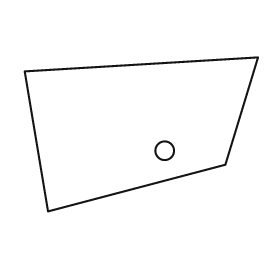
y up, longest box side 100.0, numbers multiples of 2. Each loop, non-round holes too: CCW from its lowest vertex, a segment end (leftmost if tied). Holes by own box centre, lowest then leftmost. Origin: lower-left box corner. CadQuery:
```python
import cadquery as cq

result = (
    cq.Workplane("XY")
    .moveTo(10.0, 0.0)
    .lineTo(86.0, 20.0)
    .lineTo(100.0, 66.0)
    .lineTo(0.0, 60.0)
    .close()
    .moveTo(60.0, 26.0)
    .circle(4.0)
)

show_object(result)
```